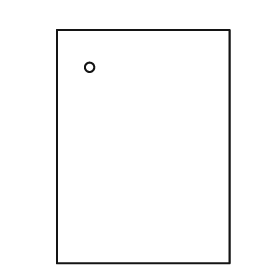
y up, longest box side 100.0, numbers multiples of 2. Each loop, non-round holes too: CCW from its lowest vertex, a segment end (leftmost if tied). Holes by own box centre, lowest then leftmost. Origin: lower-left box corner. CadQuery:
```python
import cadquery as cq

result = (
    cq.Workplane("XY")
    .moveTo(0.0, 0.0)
    .lineTo(74.0, 0.0)
    .lineTo(74.0, 100.0)
    .lineTo(0.0, 100.0)
    .close()
    .moveTo(14.0, 84.0)
    .circle(2.0)
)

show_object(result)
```